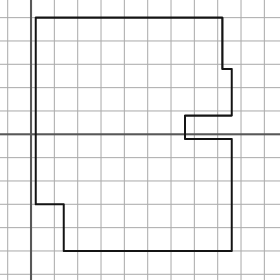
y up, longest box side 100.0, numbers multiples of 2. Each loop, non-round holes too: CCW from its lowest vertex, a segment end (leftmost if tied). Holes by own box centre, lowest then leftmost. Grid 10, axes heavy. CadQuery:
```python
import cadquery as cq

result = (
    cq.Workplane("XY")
    .moveTo(14.0, -50.0)
    .lineTo(86.0, -50.0)
    .lineTo(86.0, -2.0)
    .lineTo(66.0, -2.0)
    .lineTo(66.0, 8.0)
    .lineTo(86.0, 8.0)
    .lineTo(86.0, 28.0)
    .lineTo(82.0, 28.0)
    .lineTo(82.0, 50.0)
    .lineTo(2.0, 50.0)
    .lineTo(2.0, -30.0)
    .lineTo(14.0, -30.0)
    .close()
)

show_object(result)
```